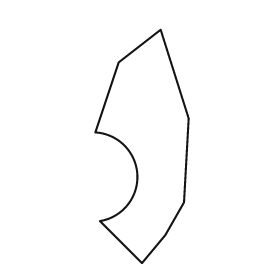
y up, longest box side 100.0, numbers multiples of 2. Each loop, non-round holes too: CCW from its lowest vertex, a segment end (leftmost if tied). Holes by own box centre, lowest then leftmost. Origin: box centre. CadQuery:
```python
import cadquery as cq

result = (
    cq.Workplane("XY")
    .moveTo(0.0, -50.0)
    .lineTo(10.0, -38.0)
    .lineTo(18.0, -24.0)
    .lineTo(20.0, 12.0)
    .lineTo(8.0, 50.0)
    .lineTo(-10.0, 36.0)
    .lineTo(-20.0, 6.0)
    .threePointArc((-2.0, -12.0), (-18.0, -32.0))
    .close()
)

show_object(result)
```